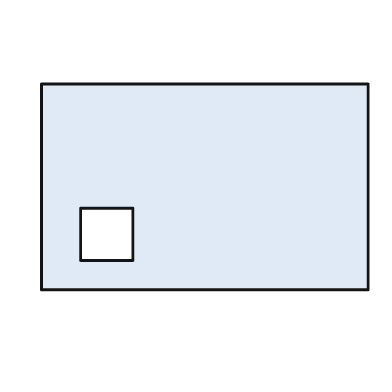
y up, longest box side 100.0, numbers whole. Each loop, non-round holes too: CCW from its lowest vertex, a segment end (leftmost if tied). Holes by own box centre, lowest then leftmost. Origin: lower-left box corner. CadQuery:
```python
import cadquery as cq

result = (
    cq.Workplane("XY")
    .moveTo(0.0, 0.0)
    .lineTo(100.0, 0.0)
    .lineTo(100.0, 63.0)
    .lineTo(0.0, 63.0)
    .close()
    .moveTo(12.0, 9.0)
    .lineTo(28.0, 9.0)
    .lineTo(28.0, 25.0)
    .lineTo(12.0, 25.0)
    .close()
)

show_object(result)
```